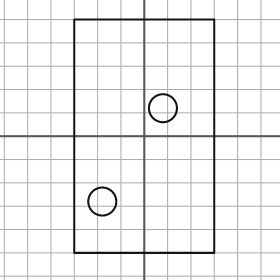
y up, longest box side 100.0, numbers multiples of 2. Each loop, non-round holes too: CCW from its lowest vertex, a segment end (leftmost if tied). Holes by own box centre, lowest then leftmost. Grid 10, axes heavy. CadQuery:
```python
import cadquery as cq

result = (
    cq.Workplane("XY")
    .moveTo(-30.0, -50.0)
    .lineTo(30.0, -50.0)
    .lineTo(30.0, 50.0)
    .lineTo(-30.0, 50.0)
    .close()
    .moveTo(-18.0, -28.0)
    .circle(6.0)
    .moveTo(8.0, 12.0)
    .circle(6.0)
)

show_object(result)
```